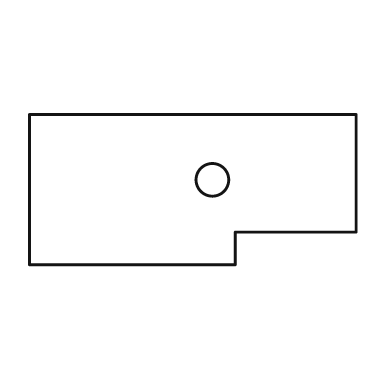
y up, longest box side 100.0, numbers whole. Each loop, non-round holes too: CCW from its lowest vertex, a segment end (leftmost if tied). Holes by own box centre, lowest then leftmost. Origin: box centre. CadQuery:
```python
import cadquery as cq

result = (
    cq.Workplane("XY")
    .moveTo(-50.0, -23.0)
    .lineTo(13.0, -23.0)
    .lineTo(13.0, -13.0)
    .lineTo(50.0, -13.0)
    .lineTo(50.0, 23.0)
    .lineTo(-50.0, 23.0)
    .close()
    .moveTo(6.0, 3.0)
    .circle(5.0)
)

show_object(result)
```